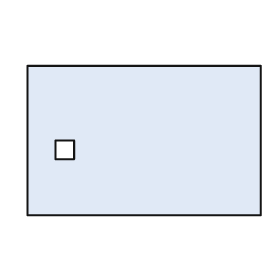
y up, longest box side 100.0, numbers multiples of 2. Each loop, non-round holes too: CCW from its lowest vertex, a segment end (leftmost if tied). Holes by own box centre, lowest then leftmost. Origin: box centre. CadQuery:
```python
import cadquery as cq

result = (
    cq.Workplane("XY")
    .moveTo(-50.0, -32.0)
    .lineTo(50.0, -32.0)
    .lineTo(50.0, 32.0)
    .lineTo(-50.0, 32.0)
    .close()
    .moveTo(-38.0, -8.0)
    .lineTo(-30.0, -8.0)
    .lineTo(-30.0, 0.0)
    .lineTo(-38.0, 0.0)
    .close()
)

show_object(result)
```